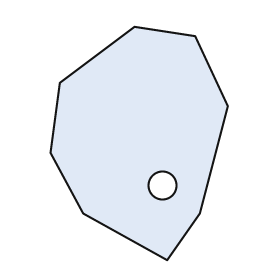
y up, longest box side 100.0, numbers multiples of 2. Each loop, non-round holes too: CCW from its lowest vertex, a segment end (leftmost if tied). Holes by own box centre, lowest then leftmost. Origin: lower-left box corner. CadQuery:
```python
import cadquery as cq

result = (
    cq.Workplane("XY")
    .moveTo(50.0, 0.0)
    .lineTo(64.0, 20.0)
    .lineTo(76.0, 66.0)
    .lineTo(62.0, 96.0)
    .lineTo(36.0, 100.0)
    .lineTo(4.0, 76.0)
    .lineTo(0.0, 46.0)
    .lineTo(14.0, 20.0)
    .close()
    .moveTo(48.0, 32.0)
    .circle(6.0)
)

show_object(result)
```